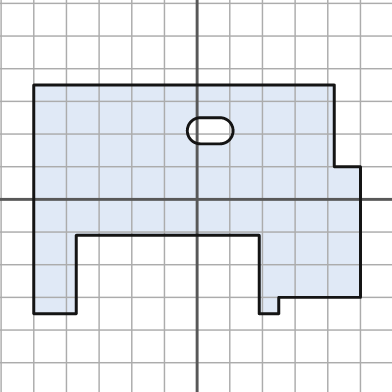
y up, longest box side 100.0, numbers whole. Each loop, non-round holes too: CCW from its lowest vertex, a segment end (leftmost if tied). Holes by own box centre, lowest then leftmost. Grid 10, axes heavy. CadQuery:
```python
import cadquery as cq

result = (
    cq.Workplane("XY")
    .moveTo(-50.0, -35.0)
    .lineTo(-37.0, -35.0)
    .lineTo(-37.0, -11.0)
    .lineTo(19.0, -11.0)
    .lineTo(19.0, -35.0)
    .lineTo(25.0, -35.0)
    .lineTo(25.0, -30.0)
    .lineTo(50.0, -30.0)
    .lineTo(50.0, 10.0)
    .lineTo(42.0, 10.0)
    .lineTo(42.0, 35.0)
    .lineTo(-50.0, 35.0)
    .close()
    .moveTo(1.0, 17.0)
    .lineTo(7.0, 17.0)
    .threePointArc((11.0, 21.0), (7.0, 25.0))
    .lineTo(1.0, 25.0)
    .threePointArc((-3.0, 21.0), (1.0, 17.0))
    .close()
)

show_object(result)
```